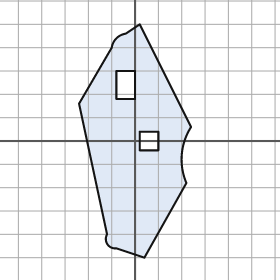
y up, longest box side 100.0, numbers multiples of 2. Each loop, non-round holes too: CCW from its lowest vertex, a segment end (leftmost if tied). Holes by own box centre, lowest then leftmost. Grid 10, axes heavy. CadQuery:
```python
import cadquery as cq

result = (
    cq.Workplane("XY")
    .moveTo(4.0, -50.0)
    .lineTo(22.0, -18.0)
    .threePointArc((20.0, -6.0), (24.0, 6.0))
    .lineTo(2.0, 50.0)
    .lineTo(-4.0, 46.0)
    .threePointArc((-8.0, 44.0), (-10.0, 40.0))
    .lineTo(-24.0, 16.0)
    .lineTo(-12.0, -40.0)
    .threePointArc((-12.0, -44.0), (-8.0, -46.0))
    .close()
    .moveTo(2.0, -4.0)
    .lineTo(10.0, -4.0)
    .lineTo(10.0, 4.0)
    .lineTo(2.0, 4.0)
    .close()
    .moveTo(-8.0, 18.0)
    .lineTo(0.0, 18.0)
    .lineTo(0.0, 30.0)
    .lineTo(-8.0, 30.0)
    .close()
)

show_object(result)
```